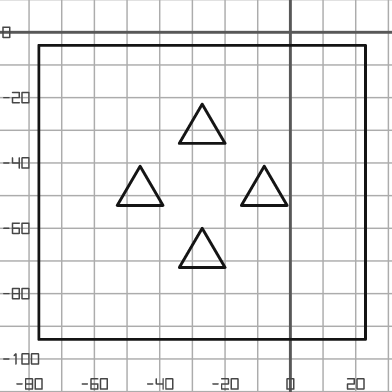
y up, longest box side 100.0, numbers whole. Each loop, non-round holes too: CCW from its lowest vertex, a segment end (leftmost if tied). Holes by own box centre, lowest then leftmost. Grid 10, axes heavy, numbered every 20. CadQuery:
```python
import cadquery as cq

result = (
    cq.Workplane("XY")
    .moveTo(-77.0, -94.0)
    .lineTo(23.0, -94.0)
    .lineTo(23.0, -4.0)
    .lineTo(-77.0, -4.0)
    .close()
    .moveTo(-34.0, -72.0)
    .lineTo(-20.0, -72.0)
    .lineTo(-27.0, -60.0)
    .close()
    .moveTo(-53.0, -53.0)
    .lineTo(-39.0, -53.0)
    .lineTo(-46.0, -41.0)
    .close()
    .moveTo(-15.0, -53.0)
    .lineTo(-1.0, -53.0)
    .lineTo(-8.0, -41.0)
    .close()
    .moveTo(-34.0, -34.0)
    .lineTo(-20.0, -34.0)
    .lineTo(-27.0, -22.0)
    .close()
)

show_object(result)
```